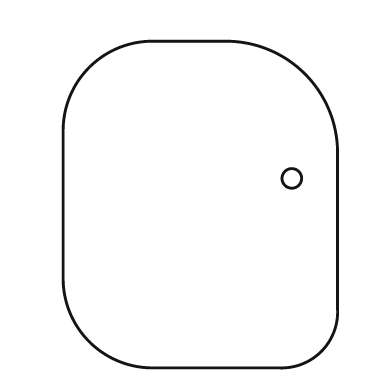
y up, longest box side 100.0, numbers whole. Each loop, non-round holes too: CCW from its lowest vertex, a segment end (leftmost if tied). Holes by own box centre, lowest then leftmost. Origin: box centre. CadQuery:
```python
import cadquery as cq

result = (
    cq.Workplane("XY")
    .moveTo(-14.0, -50.0)
    .lineTo(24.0, -50.0)
    .threePointArc((37.0, -45.0), (42.0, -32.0))
    .lineTo(42.0, 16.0)
    .threePointArc((32.0, 40.0), (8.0, 50.0))
    .lineTo(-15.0, 50.0)
    .threePointArc((-34.0, 42.0), (-42.0, 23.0))
    .lineTo(-42.0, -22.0)
    .threePointArc((-34.0, -42.0), (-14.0, -50.0))
    .close()
    .moveTo(28.0, 8.0)
    .circle(3.0)
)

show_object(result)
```